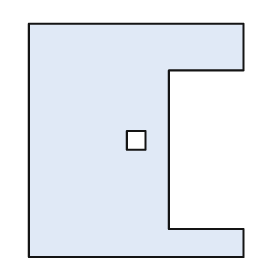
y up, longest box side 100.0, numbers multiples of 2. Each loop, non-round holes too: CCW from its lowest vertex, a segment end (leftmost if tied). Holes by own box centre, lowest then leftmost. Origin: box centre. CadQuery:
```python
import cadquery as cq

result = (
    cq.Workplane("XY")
    .moveTo(-46.0, -50.0)
    .lineTo(46.0, -50.0)
    .lineTo(46.0, -38.0)
    .lineTo(14.0, -38.0)
    .lineTo(14.0, 30.0)
    .lineTo(46.0, 30.0)
    .lineTo(46.0, 50.0)
    .lineTo(-46.0, 50.0)
    .close()
    .moveTo(-4.0, -4.0)
    .lineTo(4.0, -4.0)
    .lineTo(4.0, 4.0)
    .lineTo(-4.0, 4.0)
    .close()
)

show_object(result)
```